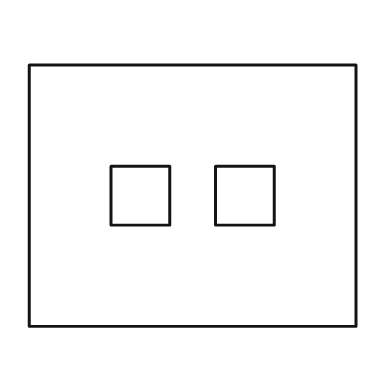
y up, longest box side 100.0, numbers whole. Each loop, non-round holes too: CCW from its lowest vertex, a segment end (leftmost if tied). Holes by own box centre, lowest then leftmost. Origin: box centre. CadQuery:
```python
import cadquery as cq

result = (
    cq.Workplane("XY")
    .moveTo(-50.0, -40.0)
    .lineTo(50.0, -40.0)
    .lineTo(50.0, 40.0)
    .lineTo(-50.0, 40.0)
    .close()
    .moveTo(-25.0, -9.0)
    .lineTo(-7.0, -9.0)
    .lineTo(-7.0, 9.0)
    .lineTo(-25.0, 9.0)
    .close()
    .moveTo(7.0, -9.0)
    .lineTo(25.0, -9.0)
    .lineTo(25.0, 9.0)
    .lineTo(7.0, 9.0)
    .close()
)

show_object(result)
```